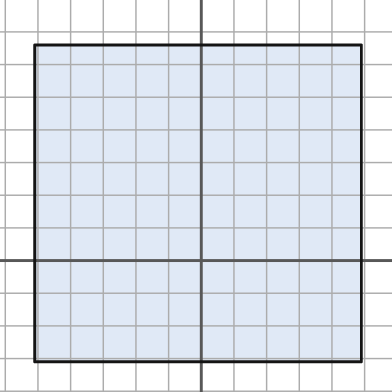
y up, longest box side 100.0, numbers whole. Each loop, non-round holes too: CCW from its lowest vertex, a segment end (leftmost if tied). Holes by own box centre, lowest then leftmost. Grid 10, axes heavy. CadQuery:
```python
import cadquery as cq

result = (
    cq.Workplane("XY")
    .moveTo(-51.0, -31.0)
    .lineTo(49.0, -31.0)
    .lineTo(49.0, 66.0)
    .lineTo(-51.0, 66.0)
    .close()
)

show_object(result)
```